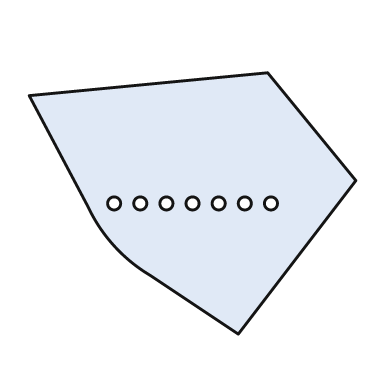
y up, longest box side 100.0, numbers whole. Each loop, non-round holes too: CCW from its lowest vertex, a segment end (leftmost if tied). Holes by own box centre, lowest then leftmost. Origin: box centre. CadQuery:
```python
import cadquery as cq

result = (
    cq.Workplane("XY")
    .moveTo(14.0, -40.0)
    .lineTo(50.0, 7.0)
    .lineTo(23.0, 40.0)
    .lineTo(-50.0, 33.0)
    .lineTo(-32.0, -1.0)
    .threePointArc((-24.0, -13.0), (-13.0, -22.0))
    .close()
    .moveTo(-24.0, 0.0)
    .circle(2.0)
    .moveTo(-16.0, 0.0)
    .circle(2.0)
    .moveTo(-8.0, 0.0)
    .circle(2.0)
    .moveTo(0.0, 0.0)
    .circle(2.0)
    .moveTo(8.0, 0.0)
    .circle(2.0)
    .moveTo(16.0, 0.0)
    .circle(2.0)
    .moveTo(24.0, 0.0)
    .circle(2.0)
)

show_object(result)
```